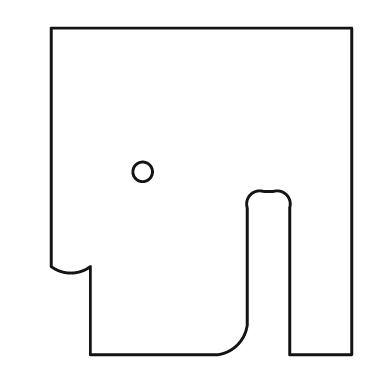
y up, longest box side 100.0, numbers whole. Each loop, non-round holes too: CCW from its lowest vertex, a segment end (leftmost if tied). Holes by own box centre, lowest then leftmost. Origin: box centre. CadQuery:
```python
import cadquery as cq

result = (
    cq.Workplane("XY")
    .moveTo(-34.0, -50.0)
    .lineTo(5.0, -50.0)
    .threePointArc((11.0, -47.0), (14.0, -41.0))
    .lineTo(14.0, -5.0)
    .threePointArc((15.0, -1.0), (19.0, 0.0))
    .lineTo(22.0, 0.0)
    .threePointArc((26.0, -1.0), (27.0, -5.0))
    .lineTo(27.0, -50.0)
    .lineTo(46.0, -50.0)
    .lineTo(46.0, 50.0)
    .lineTo(-46.0, 50.0)
    .lineTo(-46.0, -23.0)
    .threePointArc((-40.0, -25.0), (-34.0, -23.0))
    .close()
    .moveTo(-18.0, 6.0)
    .circle(3.0)
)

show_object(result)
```